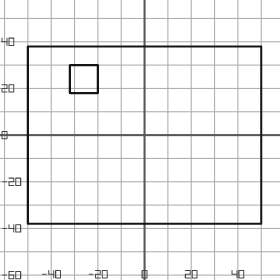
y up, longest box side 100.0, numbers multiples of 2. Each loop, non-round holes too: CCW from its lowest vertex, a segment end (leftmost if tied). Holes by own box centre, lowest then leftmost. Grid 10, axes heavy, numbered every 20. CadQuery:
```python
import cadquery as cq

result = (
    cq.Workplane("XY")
    .moveTo(-50.0, -38.0)
    .lineTo(50.0, -38.0)
    .lineTo(50.0, 38.0)
    .lineTo(-50.0, 38.0)
    .close()
    .moveTo(-32.0, 18.0)
    .lineTo(-20.0, 18.0)
    .lineTo(-20.0, 30.0)
    .lineTo(-32.0, 30.0)
    .close()
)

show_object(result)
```